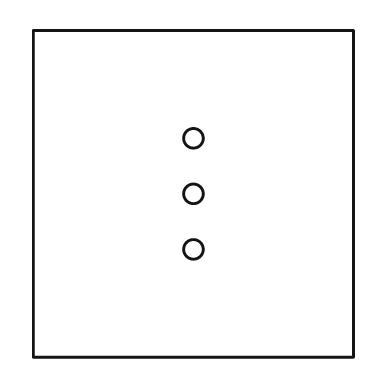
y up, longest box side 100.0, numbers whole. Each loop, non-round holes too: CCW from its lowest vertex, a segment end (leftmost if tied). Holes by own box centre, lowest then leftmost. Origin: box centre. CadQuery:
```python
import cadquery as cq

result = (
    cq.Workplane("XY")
    .moveTo(-49.0, -50.0)
    .lineTo(49.0, -50.0)
    .lineTo(49.0, 50.0)
    .lineTo(-49.0, 50.0)
    .close()
    .moveTo(0.0, -17.0)
    .circle(3.0)
    .moveTo(0.0, 0.0)
    .circle(3.0)
    .moveTo(0.0, 17.0)
    .circle(3.0)
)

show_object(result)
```